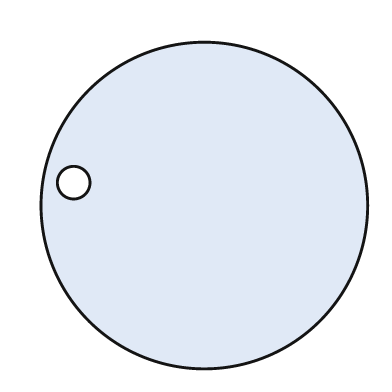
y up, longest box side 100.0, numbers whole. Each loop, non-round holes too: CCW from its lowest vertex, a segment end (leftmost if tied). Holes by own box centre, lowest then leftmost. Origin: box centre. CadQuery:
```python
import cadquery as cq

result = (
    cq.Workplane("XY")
    .moveTo(0.0, 0.0)
    .circle(50.0)
    .moveTo(-40.0, 7.0)
    .circle(5.0)
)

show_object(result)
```